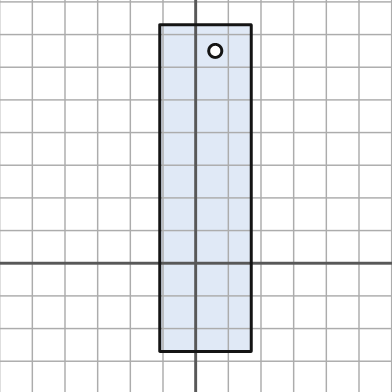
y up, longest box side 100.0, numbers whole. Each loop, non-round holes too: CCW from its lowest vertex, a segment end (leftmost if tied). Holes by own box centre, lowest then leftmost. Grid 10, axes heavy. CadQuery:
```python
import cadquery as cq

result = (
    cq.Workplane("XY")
    .moveTo(-11.0, -27.0)
    .lineTo(17.0, -27.0)
    .lineTo(17.0, 73.0)
    .lineTo(-11.0, 73.0)
    .close()
    .moveTo(6.0, 65.0)
    .circle(2.0)
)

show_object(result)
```